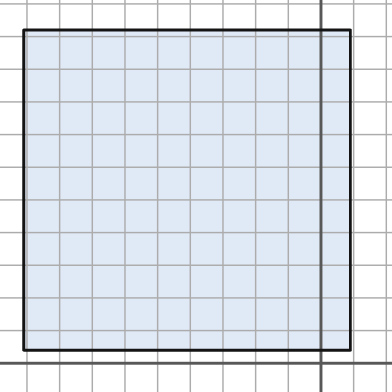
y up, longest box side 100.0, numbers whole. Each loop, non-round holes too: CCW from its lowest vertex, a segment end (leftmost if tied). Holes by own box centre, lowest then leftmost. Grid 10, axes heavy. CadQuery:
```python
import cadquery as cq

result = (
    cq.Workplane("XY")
    .moveTo(-91.0, 4.0)
    .lineTo(9.0, 4.0)
    .lineTo(9.0, 102.0)
    .lineTo(-91.0, 102.0)
    .close()
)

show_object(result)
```